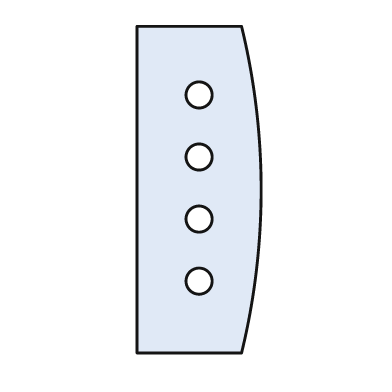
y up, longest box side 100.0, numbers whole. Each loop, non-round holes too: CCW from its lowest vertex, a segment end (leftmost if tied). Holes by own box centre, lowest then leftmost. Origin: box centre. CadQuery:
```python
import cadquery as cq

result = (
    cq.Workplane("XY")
    .moveTo(-19.0, -50.0)
    .lineTo(13.0, -50.0)
    .threePointArc((19.0, 0.0), (13.0, 50.0))
    .lineTo(-19.0, 50.0)
    .close()
    .moveTo(0.0, -28.0)
    .circle(4.0)
    .moveTo(0.0, -9.0)
    .circle(4.0)
    .moveTo(0.0, 10.0)
    .circle(4.0)
    .moveTo(0.0, 29.0)
    .circle(4.0)
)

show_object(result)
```